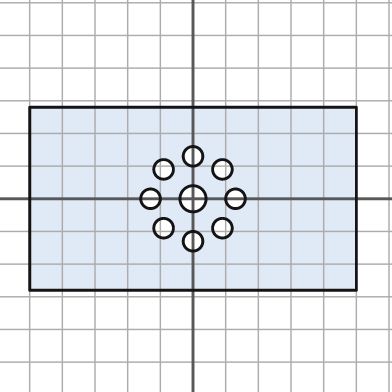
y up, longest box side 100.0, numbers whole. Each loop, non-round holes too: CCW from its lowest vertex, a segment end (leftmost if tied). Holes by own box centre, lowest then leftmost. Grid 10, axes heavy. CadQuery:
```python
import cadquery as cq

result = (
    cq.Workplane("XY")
    .moveTo(-50.0, -28.0)
    .lineTo(50.0, -28.0)
    .lineTo(50.0, 28.0)
    .lineTo(-50.0, 28.0)
    .close()
    .moveTo(0.0, -13.0)
    .circle(3.0)
    .moveTo(-9.0, -9.0)
    .circle(3.0)
    .moveTo(9.0, -9.0)
    .circle(3.0)
    .moveTo(-13.0, 0.0)
    .circle(3.0)
    .moveTo(0.0, 0.0)
    .circle(4.0)
    .moveTo(13.0, 0.0)
    .circle(3.0)
    .moveTo(-9.0, 9.0)
    .circle(3.0)
    .moveTo(9.0, 9.0)
    .circle(3.0)
    .moveTo(0.0, 13.0)
    .circle(3.0)
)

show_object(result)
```